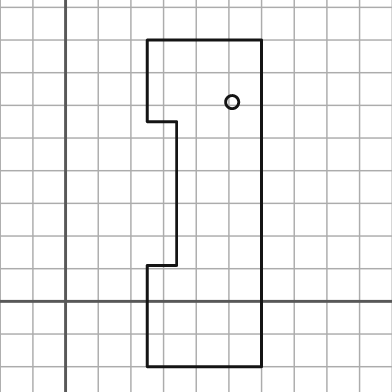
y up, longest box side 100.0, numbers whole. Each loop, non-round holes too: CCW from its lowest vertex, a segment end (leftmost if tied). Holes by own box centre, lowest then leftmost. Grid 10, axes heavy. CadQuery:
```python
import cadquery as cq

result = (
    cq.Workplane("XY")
    .moveTo(25.0, -20.0)
    .lineTo(60.0, -20.0)
    .lineTo(60.0, 80.0)
    .lineTo(25.0, 80.0)
    .lineTo(25.0, 55.0)
    .lineTo(34.0, 55.0)
    .lineTo(34.0, 11.0)
    .lineTo(25.0, 11.0)
    .close()
    .moveTo(51.0, 61.0)
    .circle(2.0)
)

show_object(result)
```